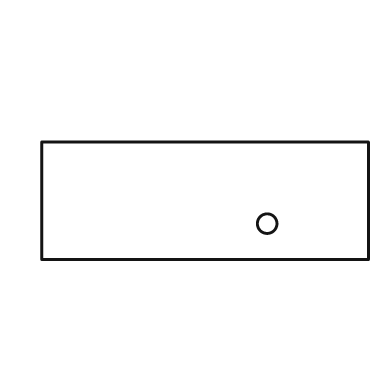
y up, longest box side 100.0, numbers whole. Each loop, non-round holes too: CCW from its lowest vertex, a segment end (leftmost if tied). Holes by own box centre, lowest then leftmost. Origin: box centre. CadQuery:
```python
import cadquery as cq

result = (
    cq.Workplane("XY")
    .moveTo(-50.0, -18.0)
    .lineTo(50.0, -18.0)
    .lineTo(50.0, 18.0)
    .lineTo(-50.0, 18.0)
    .close()
    .moveTo(19.0, -7.0)
    .circle(3.0)
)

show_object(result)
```